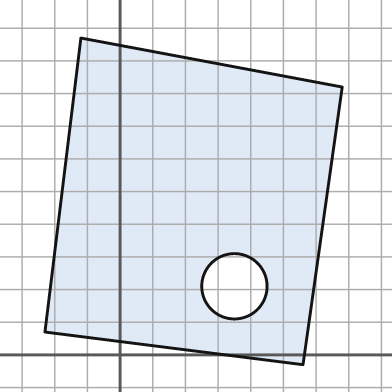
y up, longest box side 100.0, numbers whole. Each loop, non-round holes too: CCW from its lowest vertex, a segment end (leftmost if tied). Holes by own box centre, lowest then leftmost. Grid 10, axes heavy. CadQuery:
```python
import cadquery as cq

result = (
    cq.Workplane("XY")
    .moveTo(56.0, -3.0)
    .lineTo(68.0, 82.0)
    .lineTo(-12.0, 97.0)
    .lineTo(-23.0, 7.0)
    .close()
    .moveTo(35.0, 21.0)
    .circle(10.0)
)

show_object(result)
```